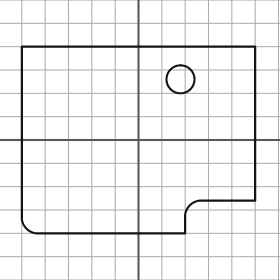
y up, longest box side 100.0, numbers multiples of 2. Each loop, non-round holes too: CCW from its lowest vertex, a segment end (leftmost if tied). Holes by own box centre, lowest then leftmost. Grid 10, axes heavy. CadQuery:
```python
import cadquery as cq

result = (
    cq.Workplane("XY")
    .moveTo(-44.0, -40.0)
    .lineTo(20.0, -40.0)
    .lineTo(20.0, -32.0)
    .threePointArc((22.0, -28.0), (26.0, -26.0))
    .lineTo(50.0, -26.0)
    .lineTo(50.0, 40.0)
    .lineTo(-50.0, 40.0)
    .lineTo(-50.0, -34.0)
    .threePointArc((-48.0, -38.0), (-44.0, -40.0))
    .close()
    .moveTo(18.0, 26.0)
    .circle(6.0)
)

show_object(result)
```